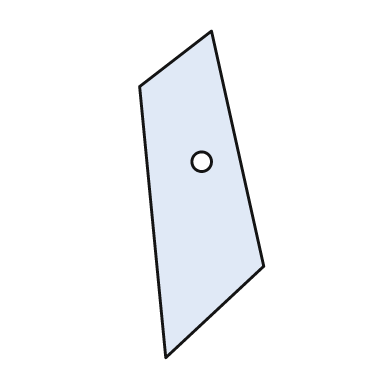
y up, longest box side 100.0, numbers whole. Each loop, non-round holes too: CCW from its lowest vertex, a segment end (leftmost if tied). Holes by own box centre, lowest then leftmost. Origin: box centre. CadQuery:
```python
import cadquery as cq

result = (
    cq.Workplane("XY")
    .moveTo(-11.0, -50.0)
    .lineTo(19.0, -22.0)
    .lineTo(3.0, 50.0)
    .lineTo(-19.0, 33.0)
    .close()
    .moveTo(0.0, 10.0)
    .circle(3.0)
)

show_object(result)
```